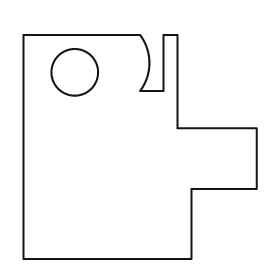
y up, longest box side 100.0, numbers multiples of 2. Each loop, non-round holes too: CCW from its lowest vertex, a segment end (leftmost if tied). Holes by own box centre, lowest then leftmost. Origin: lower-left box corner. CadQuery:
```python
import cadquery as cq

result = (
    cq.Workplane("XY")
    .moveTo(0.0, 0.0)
    .lineTo(72.0, 0.0)
    .lineTo(72.0, 30.0)
    .lineTo(100.0, 30.0)
    .lineTo(100.0, 56.0)
    .lineTo(66.0, 56.0)
    .lineTo(66.0, 96.0)
    .lineTo(60.0, 96.0)
    .lineTo(60.0, 72.0)
    .lineTo(50.0, 72.0)
    .threePointArc((54.0, 84.0), (50.0, 96.0))
    .lineTo(0.0, 96.0)
    .close()
    .moveTo(22.0, 80.0)
    .circle(10.0)
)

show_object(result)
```